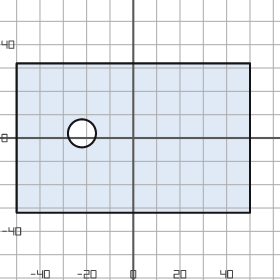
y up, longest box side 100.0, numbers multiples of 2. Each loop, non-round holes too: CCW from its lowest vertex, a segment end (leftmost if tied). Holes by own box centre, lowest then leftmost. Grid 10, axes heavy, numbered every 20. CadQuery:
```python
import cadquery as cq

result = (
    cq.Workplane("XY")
    .moveTo(-50.0, -32.0)
    .lineTo(50.0, -32.0)
    .lineTo(50.0, 32.0)
    .lineTo(-50.0, 32.0)
    .close()
    .moveTo(-22.0, 2.0)
    .circle(6.0)
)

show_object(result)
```